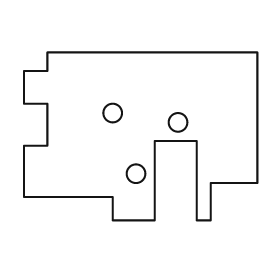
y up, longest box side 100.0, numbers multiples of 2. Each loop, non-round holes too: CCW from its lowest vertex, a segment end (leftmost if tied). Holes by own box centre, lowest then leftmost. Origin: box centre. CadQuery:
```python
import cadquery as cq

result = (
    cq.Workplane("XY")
    .moveTo(-12.0, -36.0)
    .lineTo(6.0, -36.0)
    .lineTo(6.0, -2.0)
    .lineTo(24.0, -2.0)
    .lineTo(24.0, -36.0)
    .lineTo(30.0, -36.0)
    .lineTo(30.0, -20.0)
    .lineTo(50.0, -20.0)
    .lineTo(50.0, 36.0)
    .lineTo(-40.0, 36.0)
    .lineTo(-40.0, 28.0)
    .lineTo(-50.0, 28.0)
    .lineTo(-50.0, 14.0)
    .lineTo(-40.0, 14.0)
    .lineTo(-40.0, -4.0)
    .lineTo(-50.0, -4.0)
    .lineTo(-50.0, -26.0)
    .lineTo(-12.0, -26.0)
    .close()
    .moveTo(-2.0, -16.0)
    .circle(4.0)
    .moveTo(16.0, 6.0)
    .circle(4.0)
    .moveTo(-12.0, 10.0)
    .circle(4.0)
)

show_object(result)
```